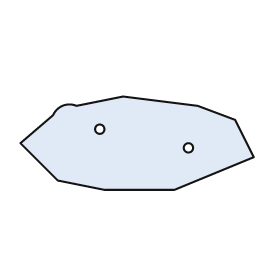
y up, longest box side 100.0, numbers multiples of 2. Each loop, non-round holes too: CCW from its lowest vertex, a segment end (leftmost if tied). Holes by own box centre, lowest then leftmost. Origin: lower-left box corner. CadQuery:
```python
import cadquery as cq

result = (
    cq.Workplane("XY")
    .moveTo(36.0, 0.0)
    .lineTo(66.0, 0.0)
    .lineTo(100.0, 14.0)
    .lineTo(92.0, 30.0)
    .lineTo(76.0, 36.0)
    .lineTo(44.0, 40.0)
    .lineTo(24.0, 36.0)
    .threePointArc((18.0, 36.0), (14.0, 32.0))
    .lineTo(0.0, 20.0)
    .lineTo(16.0, 4.0)
    .close()
    .moveTo(72.0, 18.0)
    .circle(2.0)
    .moveTo(34.0, 26.0)
    .circle(2.0)
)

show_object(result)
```